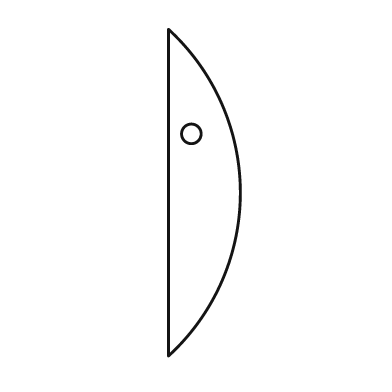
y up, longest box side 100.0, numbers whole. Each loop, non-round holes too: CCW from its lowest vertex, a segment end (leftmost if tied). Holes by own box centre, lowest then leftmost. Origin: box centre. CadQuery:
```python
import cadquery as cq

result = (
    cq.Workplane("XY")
    .moveTo(-11.0, -50.0)
    .threePointArc((11.0, 0.0), (-11.0, 50.0))
    .close()
    .moveTo(-4.0, 18.0)
    .circle(3.0)
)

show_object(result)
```